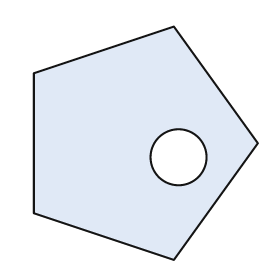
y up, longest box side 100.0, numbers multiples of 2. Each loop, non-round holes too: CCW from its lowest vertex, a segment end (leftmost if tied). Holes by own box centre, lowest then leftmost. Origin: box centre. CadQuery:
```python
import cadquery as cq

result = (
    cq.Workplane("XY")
    .moveTo(12.0, -50.0)
    .lineTo(48.0, 0.0)
    .lineTo(12.0, 50.0)
    .lineTo(-48.0, 30.0)
    .lineTo(-48.0, -30.0)
    .close()
    .moveTo(14.0, -6.0)
    .circle(12.0)
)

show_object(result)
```